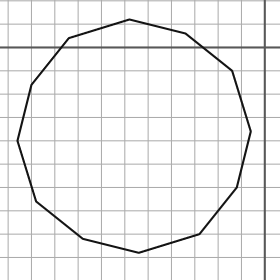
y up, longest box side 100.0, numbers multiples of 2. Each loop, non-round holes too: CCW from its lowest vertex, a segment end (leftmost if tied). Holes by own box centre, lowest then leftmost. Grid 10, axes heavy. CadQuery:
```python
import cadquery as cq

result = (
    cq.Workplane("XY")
    .moveTo(-54.0, -88.0)
    .lineTo(-28.0, -80.0)
    .lineTo(-12.0, -60.0)
    .lineTo(-6.0, -36.0)
    .lineTo(-14.0, -10.0)
    .lineTo(-34.0, 6.0)
    .lineTo(-58.0, 12.0)
    .lineTo(-84.0, 4.0)
    .lineTo(-100.0, -16.0)
    .lineTo(-106.0, -40.0)
    .lineTo(-98.0, -66.0)
    .lineTo(-78.0, -82.0)
    .close()
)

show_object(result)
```